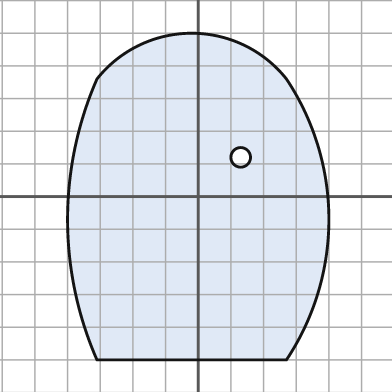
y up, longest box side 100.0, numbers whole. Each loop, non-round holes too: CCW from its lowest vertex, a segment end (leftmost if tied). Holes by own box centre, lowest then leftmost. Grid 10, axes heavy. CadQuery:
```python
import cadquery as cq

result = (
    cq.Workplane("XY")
    .moveTo(-31.0, -50.0)
    .lineTo(27.0, -50.0)
    .threePointArc((40.0, -7.0), (27.0, 36.0))
    .threePointArc((-2.0, 50.0), (-31.0, 36.0))
    .threePointArc((-40.0, -7.0), (-31.0, -50.0))
    .close()
    .moveTo(13.0, 12.0)
    .circle(3.0)
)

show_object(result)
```